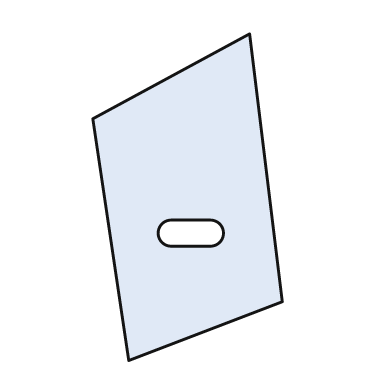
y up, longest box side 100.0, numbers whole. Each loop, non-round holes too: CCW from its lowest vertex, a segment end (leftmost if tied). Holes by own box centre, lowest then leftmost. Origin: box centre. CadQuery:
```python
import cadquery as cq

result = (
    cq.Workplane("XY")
    .moveTo(-18.0, -50.0)
    .lineTo(29.0, -32.0)
    .lineTo(19.0, 50.0)
    .lineTo(-29.0, 24.0)
    .close()
    .moveTo(-5.0, -15.0)
    .lineTo(7.0, -15.0)
    .threePointArc((11.0, -11.0), (7.0, -7.0))
    .lineTo(-5.0, -7.0)
    .threePointArc((-9.0, -11.0), (-5.0, -15.0))
    .close()
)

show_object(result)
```